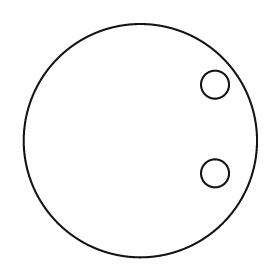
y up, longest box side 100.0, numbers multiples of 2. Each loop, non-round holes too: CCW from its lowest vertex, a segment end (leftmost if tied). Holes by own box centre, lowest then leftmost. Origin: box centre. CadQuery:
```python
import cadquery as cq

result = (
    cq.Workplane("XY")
    .moveTo(0.0, 0.0)
    .circle(50.0)
    .moveTo(32.0, -14.0)
    .circle(6.0)
    .moveTo(32.0, 24.0)
    .circle(6.0)
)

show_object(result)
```